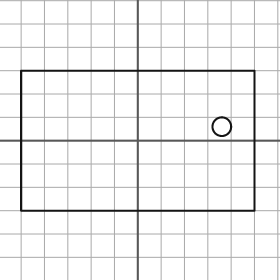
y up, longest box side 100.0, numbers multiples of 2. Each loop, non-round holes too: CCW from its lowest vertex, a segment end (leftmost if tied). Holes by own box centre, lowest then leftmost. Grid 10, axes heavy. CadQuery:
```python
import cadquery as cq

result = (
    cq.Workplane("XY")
    .moveTo(-50.0, -30.0)
    .lineTo(50.0, -30.0)
    .lineTo(50.0, 30.0)
    .lineTo(-50.0, 30.0)
    .close()
    .moveTo(36.0, 6.0)
    .circle(4.0)
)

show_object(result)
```